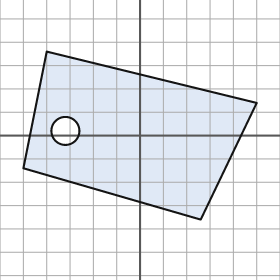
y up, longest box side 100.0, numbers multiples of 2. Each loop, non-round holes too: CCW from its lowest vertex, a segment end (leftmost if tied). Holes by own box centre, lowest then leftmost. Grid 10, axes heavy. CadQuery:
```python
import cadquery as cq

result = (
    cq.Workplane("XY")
    .moveTo(26.0, -36.0)
    .lineTo(50.0, 14.0)
    .lineTo(-40.0, 36.0)
    .lineTo(-50.0, -14.0)
    .close()
    .moveTo(-32.0, 2.0)
    .circle(6.0)
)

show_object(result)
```